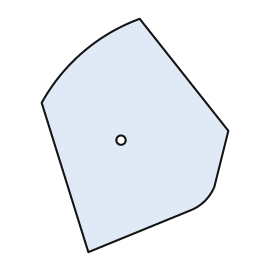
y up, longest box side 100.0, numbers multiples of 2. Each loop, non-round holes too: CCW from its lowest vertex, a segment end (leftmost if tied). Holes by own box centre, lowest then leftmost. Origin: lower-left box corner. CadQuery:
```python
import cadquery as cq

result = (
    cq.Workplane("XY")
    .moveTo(20.0, 0.0)
    .lineTo(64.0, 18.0)
    .threePointArc((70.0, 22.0), (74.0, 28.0))
    .lineTo(80.0, 52.0)
    .lineTo(42.0, 100.0)
    .threePointArc((18.0, 86.0), (0.0, 64.0))
    .close()
    .moveTo(34.0, 48.0)
    .circle(2.0)
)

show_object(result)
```